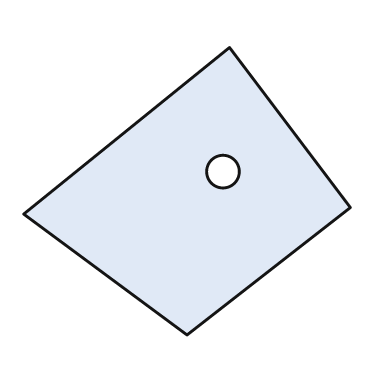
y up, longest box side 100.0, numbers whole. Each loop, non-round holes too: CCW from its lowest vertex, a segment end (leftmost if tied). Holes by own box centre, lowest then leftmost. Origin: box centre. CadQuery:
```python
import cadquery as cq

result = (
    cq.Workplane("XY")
    .moveTo(0.0, -44.0)
    .lineTo(50.0, -5.0)
    .lineTo(13.0, 44.0)
    .lineTo(-50.0, -7.0)
    .close()
    .moveTo(11.0, 6.0)
    .circle(5.0)
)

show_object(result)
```